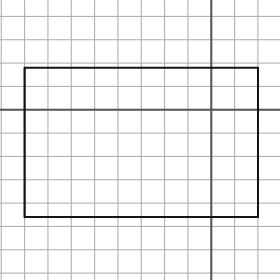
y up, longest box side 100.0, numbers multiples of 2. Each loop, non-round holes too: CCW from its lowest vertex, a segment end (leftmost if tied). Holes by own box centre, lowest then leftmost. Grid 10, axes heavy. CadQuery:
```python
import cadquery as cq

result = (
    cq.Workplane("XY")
    .moveTo(-80.0, -46.0)
    .lineTo(20.0, -46.0)
    .lineTo(20.0, 18.0)
    .lineTo(-80.0, 18.0)
    .close()
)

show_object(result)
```